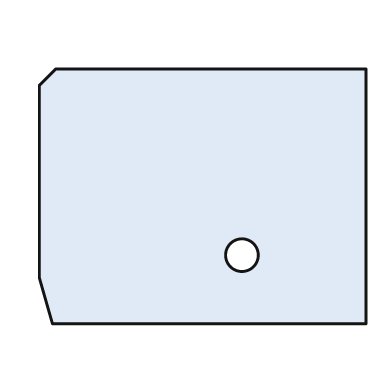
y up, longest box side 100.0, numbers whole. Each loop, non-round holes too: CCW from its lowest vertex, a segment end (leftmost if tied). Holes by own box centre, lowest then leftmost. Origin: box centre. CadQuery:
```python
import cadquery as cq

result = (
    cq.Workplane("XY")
    .moveTo(-46.0, -39.0)
    .lineTo(50.0, -39.0)
    .lineTo(50.0, 39.0)
    .lineTo(-45.0, 39.0)
    .lineTo(-50.0, 34.0)
    .lineTo(-50.0, -25.0)
    .close()
    .moveTo(12.0, -18.0)
    .circle(5.0)
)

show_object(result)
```